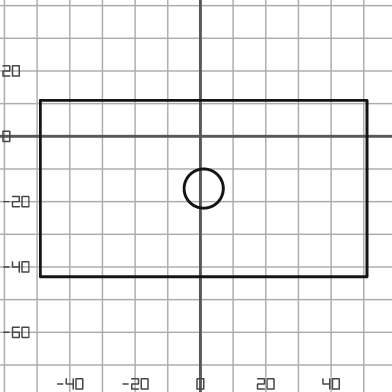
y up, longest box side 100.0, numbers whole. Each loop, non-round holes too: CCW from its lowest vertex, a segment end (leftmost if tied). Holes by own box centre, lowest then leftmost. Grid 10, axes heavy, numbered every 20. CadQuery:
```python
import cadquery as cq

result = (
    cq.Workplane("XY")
    .moveTo(-49.0, -43.0)
    .lineTo(51.0, -43.0)
    .lineTo(51.0, 11.0)
    .lineTo(-49.0, 11.0)
    .close()
    .moveTo(1.0, -16.0)
    .circle(6.0)
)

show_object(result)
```